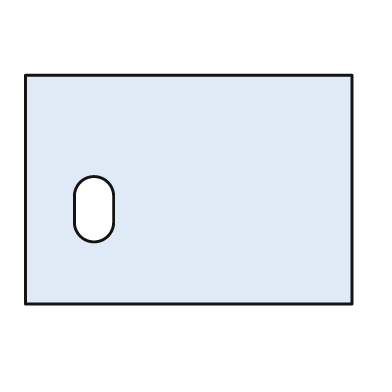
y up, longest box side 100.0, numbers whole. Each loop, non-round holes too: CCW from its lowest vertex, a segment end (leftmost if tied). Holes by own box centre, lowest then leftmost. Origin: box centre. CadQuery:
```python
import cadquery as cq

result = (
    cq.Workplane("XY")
    .moveTo(-50.0, -35.0)
    .lineTo(50.0, -35.0)
    .lineTo(50.0, 35.0)
    .lineTo(-50.0, 35.0)
    .close()
    .moveTo(-35.0, -10.0)
    .threePointArc((-29.0, -16.0), (-23.0, -10.0))
    .lineTo(-23.0, -2.0)
    .threePointArc((-29.0, 4.0), (-35.0, -2.0))
    .close()
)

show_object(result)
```